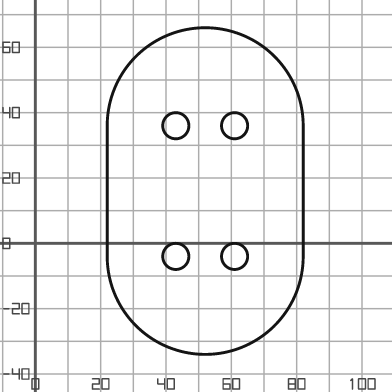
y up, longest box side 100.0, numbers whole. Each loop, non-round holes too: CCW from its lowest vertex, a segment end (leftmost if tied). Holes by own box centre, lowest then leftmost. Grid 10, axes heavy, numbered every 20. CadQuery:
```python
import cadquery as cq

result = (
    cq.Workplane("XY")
    .moveTo(22.0, -4.0)
    .threePointArc((52.0, -34.0), (82.0, -4.0))
    .lineTo(82.0, 36.0)
    .threePointArc((52.0, 66.0), (22.0, 36.0))
    .close()
    .moveTo(43.0, -4.0)
    .circle(4.0)
    .moveTo(61.0, -4.0)
    .circle(4.0)
    .moveTo(43.0, 36.0)
    .circle(4.0)
    .moveTo(61.0, 36.0)
    .circle(4.0)
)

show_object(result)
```